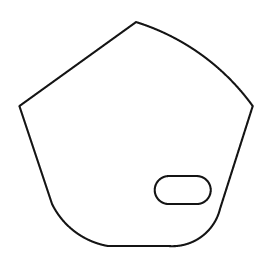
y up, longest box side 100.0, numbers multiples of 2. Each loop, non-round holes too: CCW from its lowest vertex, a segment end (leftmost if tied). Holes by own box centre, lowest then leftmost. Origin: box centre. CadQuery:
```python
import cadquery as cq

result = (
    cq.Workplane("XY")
    .moveTo(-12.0, -48.0)
    .lineTo(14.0, -48.0)
    .threePointArc((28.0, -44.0), (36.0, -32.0))
    .lineTo(50.0, 12.0)
    .threePointArc((28.0, 34.0), (0.0, 48.0))
    .lineTo(-50.0, 12.0)
    .lineTo(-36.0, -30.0)
    .threePointArc((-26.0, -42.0), (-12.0, -48.0))
    .close()
    .moveTo(14.0, -30.0)
    .lineTo(26.0, -30.0)
    .threePointArc((32.0, -24.0), (26.0, -18.0))
    .lineTo(14.0, -18.0)
    .threePointArc((8.0, -24.0), (14.0, -30.0))
    .close()
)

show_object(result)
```